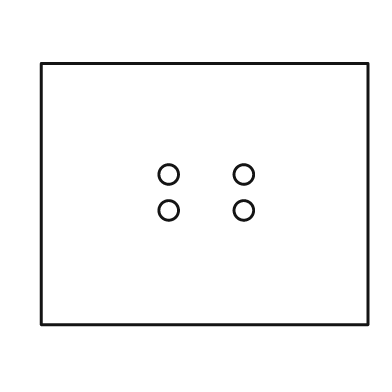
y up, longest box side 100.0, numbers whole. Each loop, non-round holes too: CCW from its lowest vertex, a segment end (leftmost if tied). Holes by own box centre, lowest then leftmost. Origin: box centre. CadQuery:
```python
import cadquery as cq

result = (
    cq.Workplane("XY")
    .moveTo(-50.0, -40.0)
    .lineTo(50.0, -40.0)
    .lineTo(50.0, 40.0)
    .lineTo(-50.0, 40.0)
    .close()
    .moveTo(-11.0, -5.0)
    .circle(3.0)
    .moveTo(12.0, -5.0)
    .circle(3.0)
    .moveTo(-11.0, 6.0)
    .circle(3.0)
    .moveTo(12.0, 6.0)
    .circle(3.0)
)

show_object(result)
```